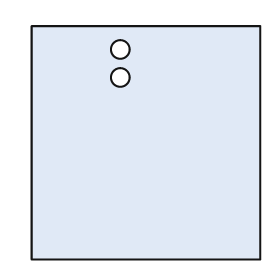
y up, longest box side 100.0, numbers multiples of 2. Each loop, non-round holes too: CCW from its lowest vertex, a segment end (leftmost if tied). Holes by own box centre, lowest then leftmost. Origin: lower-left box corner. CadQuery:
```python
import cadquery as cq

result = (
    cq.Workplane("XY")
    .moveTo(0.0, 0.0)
    .lineTo(98.0, 0.0)
    .lineTo(98.0, 100.0)
    .lineTo(0.0, 100.0)
    .close()
    .moveTo(38.0, 78.0)
    .circle(4.0)
    .moveTo(38.0, 90.0)
    .circle(4.0)
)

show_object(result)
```